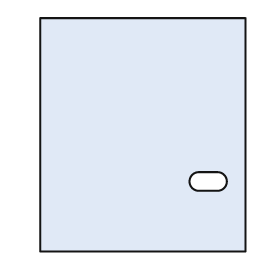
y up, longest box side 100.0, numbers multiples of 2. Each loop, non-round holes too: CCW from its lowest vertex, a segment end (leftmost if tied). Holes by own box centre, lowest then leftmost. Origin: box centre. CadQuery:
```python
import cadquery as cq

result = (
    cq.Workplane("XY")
    .moveTo(-44.0, -50.0)
    .lineTo(44.0, -50.0)
    .lineTo(44.0, 50.0)
    .lineTo(-44.0, 50.0)
    .close()
    .moveTo(24.0, -24.0)
    .lineTo(32.0, -24.0)
    .threePointArc((36.0, -20.0), (32.0, -16.0))
    .lineTo(24.0, -16.0)
    .threePointArc((20.0, -20.0), (24.0, -24.0))
    .close()
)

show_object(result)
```